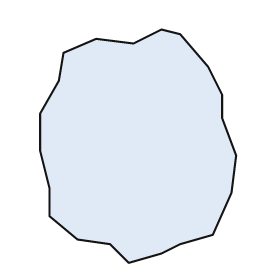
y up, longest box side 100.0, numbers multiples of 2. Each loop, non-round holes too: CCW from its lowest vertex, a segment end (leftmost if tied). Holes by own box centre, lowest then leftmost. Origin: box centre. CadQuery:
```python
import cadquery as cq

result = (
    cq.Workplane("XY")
    .moveTo(-4.0, -50.0)
    .lineTo(10.0, -46.0)
    .lineTo(18.0, -42.0)
    .lineTo(32.0, -38.0)
    .lineTo(40.0, -20.0)
    .lineTo(42.0, -4.0)
    .lineTo(36.0, 12.0)
    .lineTo(36.0, 22.0)
    .lineTo(30.0, 34.0)
    .lineTo(18.0, 48.0)
    .lineTo(10.0, 50.0)
    .lineTo(-2.0, 44.0)
    .lineTo(-18.0, 46.0)
    .lineTo(-32.0, 40.0)
    .lineTo(-34.0, 28.0)
    .lineTo(-42.0, 14.0)
    .lineTo(-42.0, -2.0)
    .lineTo(-38.0, -18.0)
    .lineTo(-38.0, -30.0)
    .lineTo(-26.0, -40.0)
    .lineTo(-12.0, -42.0)
    .close()
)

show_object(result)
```